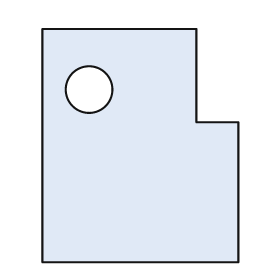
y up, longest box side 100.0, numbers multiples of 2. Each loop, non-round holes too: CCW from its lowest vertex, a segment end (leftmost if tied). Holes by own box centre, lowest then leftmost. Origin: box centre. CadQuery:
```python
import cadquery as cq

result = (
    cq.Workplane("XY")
    .moveTo(-42.0, -50.0)
    .lineTo(42.0, -50.0)
    .lineTo(42.0, 10.0)
    .lineTo(24.0, 10.0)
    .lineTo(24.0, 50.0)
    .lineTo(-42.0, 50.0)
    .close()
    .moveTo(-22.0, 24.0)
    .circle(10.0)
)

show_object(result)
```